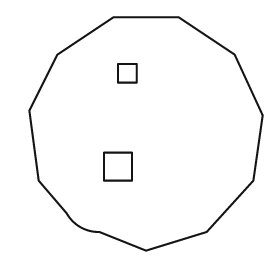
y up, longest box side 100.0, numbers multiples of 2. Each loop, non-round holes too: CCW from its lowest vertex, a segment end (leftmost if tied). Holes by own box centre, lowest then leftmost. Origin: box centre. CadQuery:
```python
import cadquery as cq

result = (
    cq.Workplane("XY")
    .moveTo(0.0, -50.0)
    .lineTo(26.0, -42.0)
    .lineTo(46.0, -20.0)
    .lineTo(50.0, 8.0)
    .lineTo(38.0, 34.0)
    .lineTo(14.0, 50.0)
    .lineTo(-14.0, 50.0)
    .lineTo(-38.0, 34.0)
    .lineTo(-50.0, 10.0)
    .lineTo(-46.0, -20.0)
    .lineTo(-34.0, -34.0)
    .threePointArc((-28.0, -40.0), (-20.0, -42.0))
    .close()
    .moveTo(-18.0, -20.0)
    .lineTo(-6.0, -20.0)
    .lineTo(-6.0, -8.0)
    .lineTo(-18.0, -8.0)
    .close()
    .moveTo(-12.0, 22.0)
    .lineTo(-4.0, 22.0)
    .lineTo(-4.0, 30.0)
    .lineTo(-12.0, 30.0)
    .close()
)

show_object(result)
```